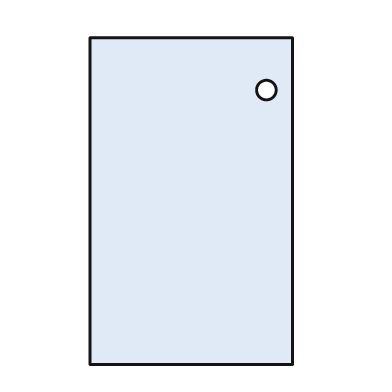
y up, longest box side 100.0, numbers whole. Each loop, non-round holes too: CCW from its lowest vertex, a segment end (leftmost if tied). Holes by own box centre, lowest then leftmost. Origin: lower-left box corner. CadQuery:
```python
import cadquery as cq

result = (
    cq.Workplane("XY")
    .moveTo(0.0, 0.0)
    .lineTo(62.0, 0.0)
    .lineTo(62.0, 100.0)
    .lineTo(0.0, 100.0)
    .close()
    .moveTo(54.0, 84.0)
    .circle(3.0)
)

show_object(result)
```